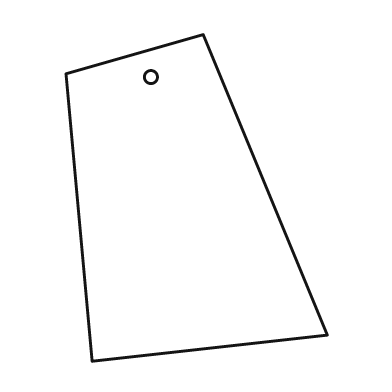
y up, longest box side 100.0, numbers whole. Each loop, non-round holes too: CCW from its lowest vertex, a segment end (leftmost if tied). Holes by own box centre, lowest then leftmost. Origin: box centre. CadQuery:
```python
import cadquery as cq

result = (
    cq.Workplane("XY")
    .moveTo(-32.0, -50.0)
    .lineTo(40.0, -42.0)
    .lineTo(2.0, 50.0)
    .lineTo(-40.0, 38.0)
    .close()
    .moveTo(-14.0, 37.0)
    .circle(2.0)
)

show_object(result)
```